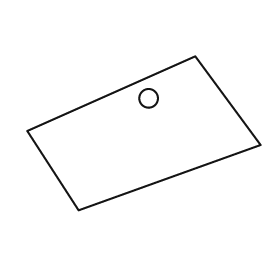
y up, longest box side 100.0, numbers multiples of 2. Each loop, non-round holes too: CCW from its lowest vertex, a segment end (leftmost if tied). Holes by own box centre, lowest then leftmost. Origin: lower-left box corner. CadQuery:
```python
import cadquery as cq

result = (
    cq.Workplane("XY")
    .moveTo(22.0, 0.0)
    .lineTo(100.0, 28.0)
    .lineTo(72.0, 66.0)
    .lineTo(0.0, 34.0)
    .close()
    .moveTo(52.0, 48.0)
    .circle(4.0)
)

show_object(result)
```